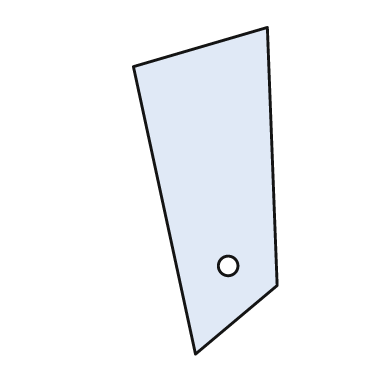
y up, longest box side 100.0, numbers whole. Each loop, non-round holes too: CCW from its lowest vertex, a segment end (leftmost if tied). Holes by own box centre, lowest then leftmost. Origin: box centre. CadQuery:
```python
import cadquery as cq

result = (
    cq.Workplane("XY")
    .moveTo(-3.0, -50.0)
    .lineTo(22.0, -29.0)
    .lineTo(19.0, 50.0)
    .lineTo(-22.0, 38.0)
    .close()
    .moveTo(7.0, -23.0)
    .circle(3.0)
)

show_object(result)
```